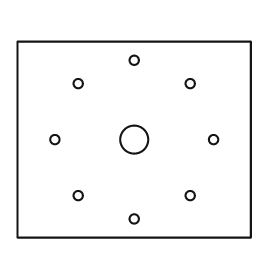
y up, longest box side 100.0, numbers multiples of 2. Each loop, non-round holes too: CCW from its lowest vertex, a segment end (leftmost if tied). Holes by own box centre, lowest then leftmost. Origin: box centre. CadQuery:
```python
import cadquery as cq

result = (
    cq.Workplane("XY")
    .moveTo(-50.0, -42.0)
    .lineTo(50.0, -42.0)
    .lineTo(50.0, 42.0)
    .lineTo(-50.0, 42.0)
    .close()
    .moveTo(0.0, -34.0)
    .circle(2.0)
    .moveTo(-24.0, -24.0)
    .circle(2.0)
    .moveTo(24.0, -24.0)
    .circle(2.0)
    .moveTo(-34.0, 0.0)
    .circle(2.0)
    .moveTo(0.0, 0.0)
    .circle(6.0)
    .moveTo(34.0, 0.0)
    .circle(2.0)
    .moveTo(-24.0, 24.0)
    .circle(2.0)
    .moveTo(24.0, 24.0)
    .circle(2.0)
    .moveTo(0.0, 34.0)
    .circle(2.0)
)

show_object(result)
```